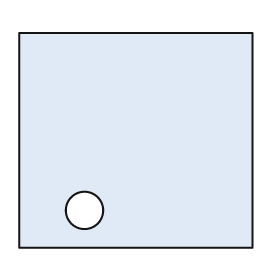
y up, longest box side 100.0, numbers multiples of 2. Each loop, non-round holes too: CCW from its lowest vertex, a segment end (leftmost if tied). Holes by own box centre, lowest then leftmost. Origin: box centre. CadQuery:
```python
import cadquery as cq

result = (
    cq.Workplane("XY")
    .moveTo(-50.0, -46.0)
    .lineTo(50.0, -46.0)
    .lineTo(50.0, 46.0)
    .lineTo(-50.0, 46.0)
    .close()
    .moveTo(-22.0, -30.0)
    .circle(8.0)
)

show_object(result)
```